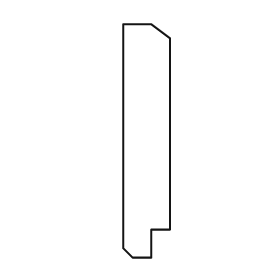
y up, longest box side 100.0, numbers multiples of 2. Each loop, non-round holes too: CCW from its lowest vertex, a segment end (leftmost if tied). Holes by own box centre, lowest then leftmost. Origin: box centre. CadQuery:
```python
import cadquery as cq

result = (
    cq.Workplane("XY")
    .moveTo(-6.0, -50.0)
    .lineTo(2.0, -50.0)
    .lineTo(2.0, -38.0)
    .lineTo(10.0, -38.0)
    .lineTo(10.0, 44.0)
    .lineTo(2.0, 50.0)
    .lineTo(-10.0, 50.0)
    .lineTo(-10.0, -46.0)
    .close()
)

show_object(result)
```